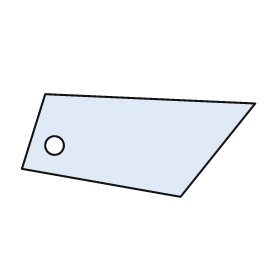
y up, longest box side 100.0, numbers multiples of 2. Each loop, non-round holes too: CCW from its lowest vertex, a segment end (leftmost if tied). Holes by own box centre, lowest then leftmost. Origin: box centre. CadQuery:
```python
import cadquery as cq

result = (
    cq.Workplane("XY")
    .moveTo(18.0, -22.0)
    .lineTo(50.0, 18.0)
    .lineTo(-40.0, 22.0)
    .lineTo(-50.0, -10.0)
    .close()
    .moveTo(-36.0, 0.0)
    .circle(4.0)
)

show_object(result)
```